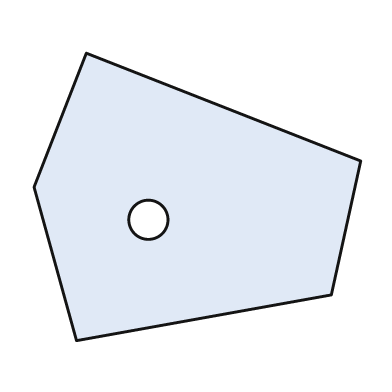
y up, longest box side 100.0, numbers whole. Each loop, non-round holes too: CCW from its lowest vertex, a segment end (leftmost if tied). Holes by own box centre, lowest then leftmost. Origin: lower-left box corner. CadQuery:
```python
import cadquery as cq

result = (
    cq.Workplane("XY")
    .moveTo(13.0, 0.0)
    .lineTo(91.0, 14.0)
    .lineTo(100.0, 55.0)
    .lineTo(16.0, 88.0)
    .lineTo(0.0, 47.0)
    .close()
    .moveTo(35.0, 37.0)
    .circle(6.0)
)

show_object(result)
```